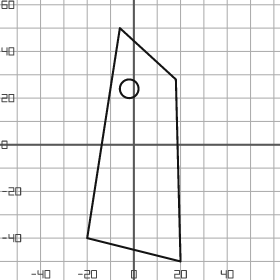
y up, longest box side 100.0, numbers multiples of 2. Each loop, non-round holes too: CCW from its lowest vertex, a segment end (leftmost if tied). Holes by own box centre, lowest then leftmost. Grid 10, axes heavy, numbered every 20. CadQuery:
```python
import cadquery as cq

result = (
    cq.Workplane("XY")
    .moveTo(20.0, -50.0)
    .lineTo(18.0, 28.0)
    .lineTo(-6.0, 50.0)
    .lineTo(-20.0, -40.0)
    .close()
    .moveTo(-2.0, 24.0)
    .circle(4.0)
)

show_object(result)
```